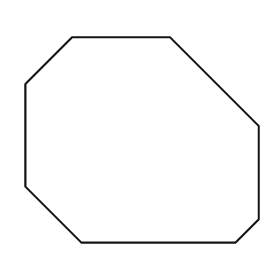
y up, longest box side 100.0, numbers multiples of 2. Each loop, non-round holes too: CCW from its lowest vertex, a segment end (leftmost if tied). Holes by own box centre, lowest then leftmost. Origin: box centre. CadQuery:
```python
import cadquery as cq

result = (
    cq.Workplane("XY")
    .moveTo(-26.0, -44.0)
    .lineTo(40.0, -44.0)
    .lineTo(50.0, -34.0)
    .lineTo(50.0, 6.0)
    .lineTo(12.0, 44.0)
    .lineTo(-30.0, 44.0)
    .lineTo(-50.0, 24.0)
    .lineTo(-50.0, -20.0)
    .close()
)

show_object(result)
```